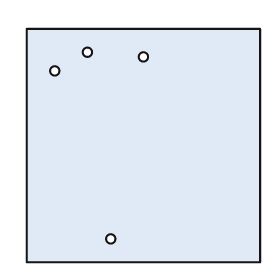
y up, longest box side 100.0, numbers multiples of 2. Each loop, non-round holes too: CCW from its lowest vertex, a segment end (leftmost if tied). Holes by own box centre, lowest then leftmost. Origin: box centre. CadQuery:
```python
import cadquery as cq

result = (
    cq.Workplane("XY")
    .moveTo(-50.0, -50.0)
    .lineTo(50.0, -50.0)
    .lineTo(50.0, 50.0)
    .lineTo(-50.0, 50.0)
    .close()
    .moveTo(-14.0, -40.0)
    .circle(2.0)
    .moveTo(-38.0, 32.0)
    .circle(2.0)
    .moveTo(0.0, 38.0)
    .circle(2.0)
    .moveTo(-24.0, 40.0)
    .circle(2.0)
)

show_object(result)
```